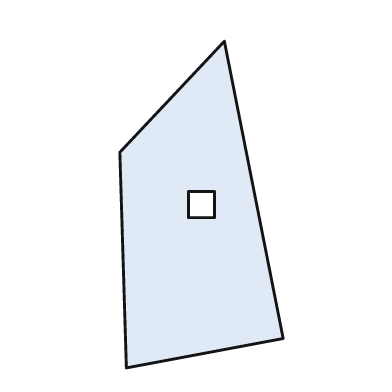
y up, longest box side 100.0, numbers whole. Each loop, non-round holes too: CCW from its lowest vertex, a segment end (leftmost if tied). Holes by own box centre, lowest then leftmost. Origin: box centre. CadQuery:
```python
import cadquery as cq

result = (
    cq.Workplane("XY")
    .moveTo(-23.0, -50.0)
    .lineTo(25.0, -41.0)
    .lineTo(7.0, 50.0)
    .lineTo(-25.0, 16.0)
    .close()
    .moveTo(-4.0, -4.0)
    .lineTo(4.0, -4.0)
    .lineTo(4.0, 4.0)
    .lineTo(-4.0, 4.0)
    .close()
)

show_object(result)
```